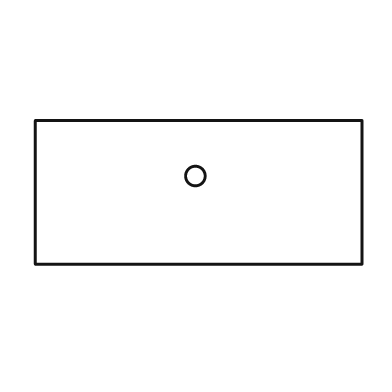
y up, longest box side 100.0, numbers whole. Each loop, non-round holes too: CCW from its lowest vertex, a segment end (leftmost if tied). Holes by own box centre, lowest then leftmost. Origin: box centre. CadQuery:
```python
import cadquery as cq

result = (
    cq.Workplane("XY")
    .moveTo(-50.0, -22.0)
    .lineTo(50.0, -22.0)
    .lineTo(50.0, 22.0)
    .lineTo(-50.0, 22.0)
    .close()
    .moveTo(-1.0, 5.0)
    .circle(3.0)
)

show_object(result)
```